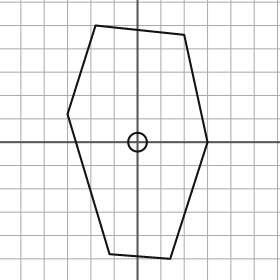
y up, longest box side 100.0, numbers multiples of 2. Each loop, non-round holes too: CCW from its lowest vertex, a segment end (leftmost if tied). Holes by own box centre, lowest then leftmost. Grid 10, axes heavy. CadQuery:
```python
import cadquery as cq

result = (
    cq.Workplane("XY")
    .moveTo(14.0, -50.0)
    .lineTo(30.0, 0.0)
    .lineTo(20.0, 46.0)
    .lineTo(-18.0, 50.0)
    .lineTo(-30.0, 12.0)
    .lineTo(-12.0, -48.0)
    .close()
    .moveTo(0.0, 0.0)
    .circle(4.0)
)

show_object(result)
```